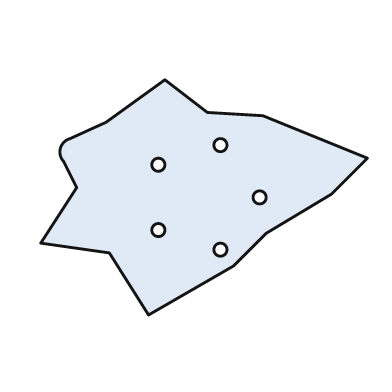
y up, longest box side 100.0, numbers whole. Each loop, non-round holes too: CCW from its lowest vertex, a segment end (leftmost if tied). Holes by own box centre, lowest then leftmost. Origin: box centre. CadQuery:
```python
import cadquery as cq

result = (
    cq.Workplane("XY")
    .moveTo(-17.0, -36.0)
    .lineTo(9.0, -21.0)
    .lineTo(19.0, -11.0)
    .lineTo(39.0, 1.0)
    .lineTo(50.0, 12.0)
    .lineTo(18.0, 25.0)
    .lineTo(1.0, 26.0)
    .lineTo(-12.0, 36.0)
    .lineTo(-30.0, 23.0)
    .lineTo(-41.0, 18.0)
    .threePointArc((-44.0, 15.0), (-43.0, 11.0))
    .lineTo(-39.0, 3.0)
    .lineTo(-50.0, -14.0)
    .lineTo(-29.0, -17.0)
    .close()
    .moveTo(5.0, -16.0)
    .circle(2.0)
    .moveTo(-14.0, -10.0)
    .circle(2.0)
    .moveTo(17.0, 0.0)
    .circle(2.0)
    .moveTo(-14.0, 10.0)
    .circle(2.0)
    .moveTo(5.0, 16.0)
    .circle(2.0)
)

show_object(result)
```